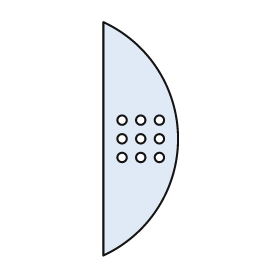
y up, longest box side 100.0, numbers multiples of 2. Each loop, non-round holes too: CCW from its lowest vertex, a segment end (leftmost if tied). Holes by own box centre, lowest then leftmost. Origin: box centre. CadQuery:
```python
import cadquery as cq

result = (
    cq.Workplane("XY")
    .moveTo(-16.0, -50.0)
    .threePointArc((16.0, 0.0), (-16.0, 50.0))
    .close()
    .moveTo(-8.0, -8.0)
    .circle(2.0)
    .moveTo(0.0, -8.0)
    .circle(2.0)
    .moveTo(8.0, -8.0)
    .circle(2.0)
    .moveTo(-8.0, 0.0)
    .circle(2.0)
    .moveTo(0.0, 0.0)
    .circle(2.0)
    .moveTo(8.0, 0.0)
    .circle(2.0)
    .moveTo(-8.0, 8.0)
    .circle(2.0)
    .moveTo(0.0, 8.0)
    .circle(2.0)
    .moveTo(8.0, 8.0)
    .circle(2.0)
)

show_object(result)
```